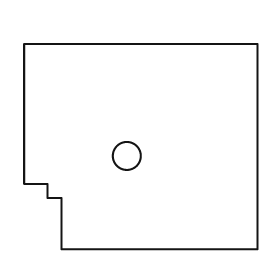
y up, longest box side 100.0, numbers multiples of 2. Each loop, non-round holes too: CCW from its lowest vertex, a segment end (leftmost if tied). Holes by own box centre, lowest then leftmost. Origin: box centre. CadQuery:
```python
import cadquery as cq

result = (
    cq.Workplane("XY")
    .moveTo(-34.0, -44.0)
    .lineTo(50.0, -44.0)
    .lineTo(50.0, 44.0)
    .lineTo(-50.0, 44.0)
    .lineTo(-50.0, -16.0)
    .lineTo(-40.0, -16.0)
    .lineTo(-40.0, -22.0)
    .lineTo(-34.0, -22.0)
    .close()
    .moveTo(-6.0, -4.0)
    .circle(6.0)
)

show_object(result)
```